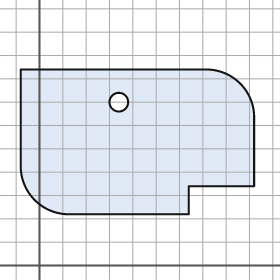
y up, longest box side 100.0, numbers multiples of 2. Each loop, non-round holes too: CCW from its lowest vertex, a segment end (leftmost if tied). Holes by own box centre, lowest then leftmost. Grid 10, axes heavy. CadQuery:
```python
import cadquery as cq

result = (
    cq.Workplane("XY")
    .moveTo(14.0, 22.0)
    .lineTo(64.0, 22.0)
    .lineTo(64.0, 34.0)
    .lineTo(92.0, 34.0)
    .lineTo(92.0, 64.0)
    .threePointArc((86.0, 78.0), (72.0, 84.0))
    .lineTo(-8.0, 84.0)
    .lineTo(-8.0, 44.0)
    .threePointArc((-2.0, 28.0), (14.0, 22.0))
    .close()
    .moveTo(34.0, 70.0)
    .circle(4.0)
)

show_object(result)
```